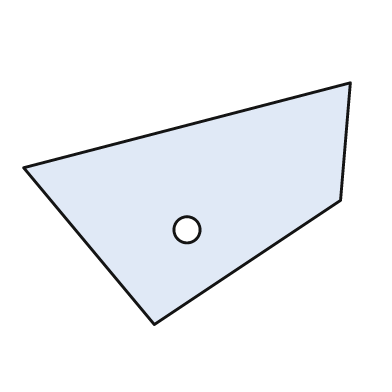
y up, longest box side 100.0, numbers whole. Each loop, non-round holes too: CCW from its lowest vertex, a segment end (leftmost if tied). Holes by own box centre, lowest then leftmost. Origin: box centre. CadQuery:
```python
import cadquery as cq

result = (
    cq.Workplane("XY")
    .moveTo(-10.0, -37.0)
    .lineTo(47.0, 1.0)
    .lineTo(50.0, 37.0)
    .lineTo(-50.0, 11.0)
    .close()
    .moveTo(0.0, -8.0)
    .circle(4.0)
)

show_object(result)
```